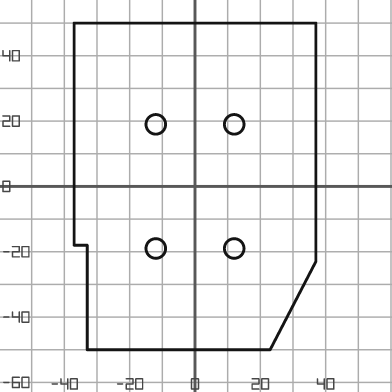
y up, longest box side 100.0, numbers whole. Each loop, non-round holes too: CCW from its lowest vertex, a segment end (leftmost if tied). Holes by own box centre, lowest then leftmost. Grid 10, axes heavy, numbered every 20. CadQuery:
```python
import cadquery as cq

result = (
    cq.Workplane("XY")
    .moveTo(-33.0, -50.0)
    .lineTo(23.0, -50.0)
    .lineTo(37.0, -23.0)
    .lineTo(37.0, 50.0)
    .lineTo(-37.0, 50.0)
    .lineTo(-37.0, -18.0)
    .lineTo(-33.0, -18.0)
    .close()
    .moveTo(-12.0, -19.0)
    .circle(3.0)
    .moveTo(12.0, -19.0)
    .circle(3.0)
    .moveTo(-12.0, 19.0)
    .circle(3.0)
    .moveTo(12.0, 19.0)
    .circle(3.0)
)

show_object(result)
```